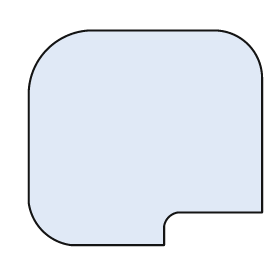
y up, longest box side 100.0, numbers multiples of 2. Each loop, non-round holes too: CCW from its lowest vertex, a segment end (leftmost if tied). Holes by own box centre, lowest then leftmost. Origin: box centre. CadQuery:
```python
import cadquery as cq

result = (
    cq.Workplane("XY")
    .moveTo(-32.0, -46.0)
    .lineTo(8.0, -46.0)
    .lineTo(8.0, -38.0)
    .threePointArc((10.0, -34.0), (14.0, -32.0))
    .lineTo(50.0, -32.0)
    .lineTo(50.0, 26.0)
    .threePointArc((44.0, 40.0), (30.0, 46.0))
    .lineTo(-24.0, 46.0)
    .threePointArc((-42.0, 38.0), (-50.0, 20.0))
    .lineTo(-50.0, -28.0)
    .threePointArc((-44.0, -40.0), (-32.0, -46.0))
    .close()
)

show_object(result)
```